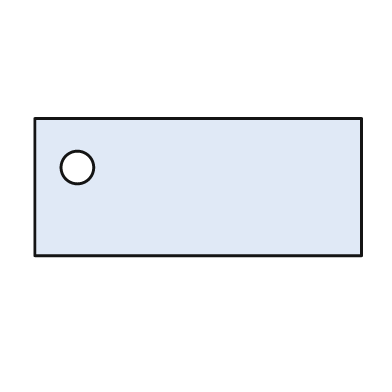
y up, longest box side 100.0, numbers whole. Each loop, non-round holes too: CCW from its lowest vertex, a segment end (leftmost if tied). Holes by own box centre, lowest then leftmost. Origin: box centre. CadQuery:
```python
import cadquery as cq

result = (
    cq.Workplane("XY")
    .moveTo(-50.0, -21.0)
    .lineTo(50.0, -21.0)
    .lineTo(50.0, 21.0)
    .lineTo(-50.0, 21.0)
    .close()
    .moveTo(-37.0, 6.0)
    .circle(5.0)
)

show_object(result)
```